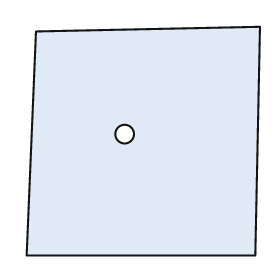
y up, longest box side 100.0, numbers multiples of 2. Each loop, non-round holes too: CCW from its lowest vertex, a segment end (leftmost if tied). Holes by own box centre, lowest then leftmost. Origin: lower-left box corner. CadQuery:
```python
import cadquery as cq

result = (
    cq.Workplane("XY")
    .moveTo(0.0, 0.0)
    .lineTo(98.0, 0.0)
    .lineTo(100.0, 98.0)
    .lineTo(4.0, 96.0)
    .close()
    .moveTo(42.0, 52.0)
    .circle(4.0)
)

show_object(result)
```